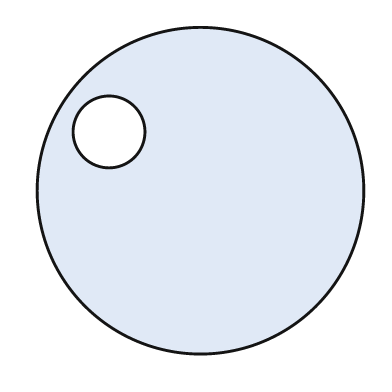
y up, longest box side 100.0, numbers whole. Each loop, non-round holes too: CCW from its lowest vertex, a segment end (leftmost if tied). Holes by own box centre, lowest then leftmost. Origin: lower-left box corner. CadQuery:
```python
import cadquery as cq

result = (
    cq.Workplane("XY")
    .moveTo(50.0, 50.0)
    .circle(50.0)
    .moveTo(22.0, 68.0)
    .circle(11.0)
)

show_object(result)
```